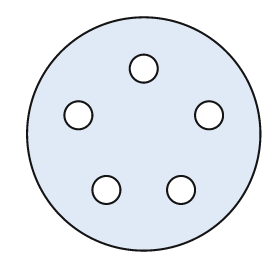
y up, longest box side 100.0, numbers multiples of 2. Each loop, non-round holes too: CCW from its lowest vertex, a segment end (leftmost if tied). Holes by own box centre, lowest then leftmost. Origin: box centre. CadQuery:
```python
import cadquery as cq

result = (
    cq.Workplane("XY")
    .moveTo(0.0, 0.0)
    .circle(50.0)
    .moveTo(-16.0, -24.0)
    .circle(6.0)
    .moveTo(16.0, -24.0)
    .circle(6.0)
    .moveTo(-28.0, 8.0)
    .circle(6.0)
    .moveTo(28.0, 8.0)
    .circle(6.0)
    .moveTo(0.0, 28.0)
    .circle(6.0)
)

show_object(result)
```